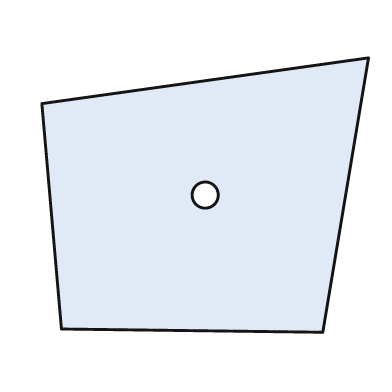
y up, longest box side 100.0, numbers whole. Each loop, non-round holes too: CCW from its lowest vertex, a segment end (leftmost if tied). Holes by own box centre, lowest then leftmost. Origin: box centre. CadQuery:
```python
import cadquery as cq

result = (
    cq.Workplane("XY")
    .moveTo(36.0, -42.0)
    .lineTo(50.0, 42.0)
    .lineTo(-50.0, 28.0)
    .lineTo(-44.0, -41.0)
    .close()
    .moveTo(0.0, 0.0)
    .circle(4.0)
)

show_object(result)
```